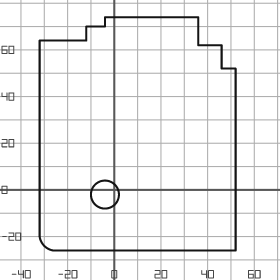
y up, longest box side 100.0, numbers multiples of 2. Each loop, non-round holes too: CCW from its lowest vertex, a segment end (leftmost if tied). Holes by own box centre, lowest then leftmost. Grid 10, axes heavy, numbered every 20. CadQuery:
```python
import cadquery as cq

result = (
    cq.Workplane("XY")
    .moveTo(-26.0, -26.0)
    .lineTo(52.0, -26.0)
    .lineTo(52.0, 52.0)
    .lineTo(46.0, 52.0)
    .lineTo(46.0, 62.0)
    .lineTo(36.0, 62.0)
    .lineTo(36.0, 74.0)
    .lineTo(-4.0, 74.0)
    .lineTo(-4.0, 70.0)
    .lineTo(-12.0, 70.0)
    .lineTo(-12.0, 64.0)
    .lineTo(-32.0, 64.0)
    .lineTo(-32.0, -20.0)
    .threePointArc((-30.0, -24.0), (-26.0, -26.0))
    .close()
    .moveTo(-4.0, -2.0)
    .circle(6.0)
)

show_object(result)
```